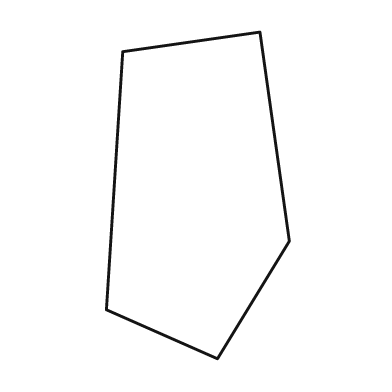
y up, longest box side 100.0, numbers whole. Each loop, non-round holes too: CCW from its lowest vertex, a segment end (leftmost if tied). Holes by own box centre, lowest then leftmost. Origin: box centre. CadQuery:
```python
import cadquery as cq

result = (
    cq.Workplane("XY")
    .moveTo(6.0, -50.0)
    .lineTo(28.0, -14.0)
    .lineTo(19.0, 50.0)
    .lineTo(-23.0, 44.0)
    .lineTo(-28.0, -35.0)
    .close()
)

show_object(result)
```